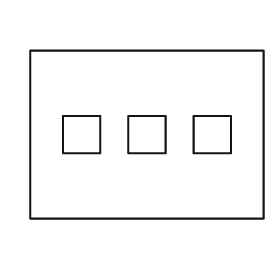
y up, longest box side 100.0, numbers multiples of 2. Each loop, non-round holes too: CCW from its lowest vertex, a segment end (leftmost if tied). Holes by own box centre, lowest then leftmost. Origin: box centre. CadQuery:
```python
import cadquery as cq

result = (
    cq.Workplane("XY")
    .moveTo(-50.0, -36.0)
    .lineTo(50.0, -36.0)
    .lineTo(50.0, 36.0)
    .lineTo(-50.0, 36.0)
    .close()
    .moveTo(-36.0, -8.0)
    .lineTo(-20.0, -8.0)
    .lineTo(-20.0, 8.0)
    .lineTo(-36.0, 8.0)
    .close()
    .moveTo(-8.0, -8.0)
    .lineTo(8.0, -8.0)
    .lineTo(8.0, 8.0)
    .lineTo(-8.0, 8.0)
    .close()
    .moveTo(20.0, -8.0)
    .lineTo(36.0, -8.0)
    .lineTo(36.0, 8.0)
    .lineTo(20.0, 8.0)
    .close()
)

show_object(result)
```